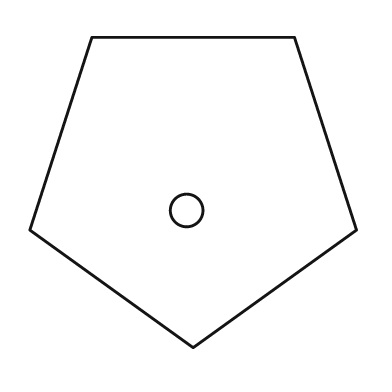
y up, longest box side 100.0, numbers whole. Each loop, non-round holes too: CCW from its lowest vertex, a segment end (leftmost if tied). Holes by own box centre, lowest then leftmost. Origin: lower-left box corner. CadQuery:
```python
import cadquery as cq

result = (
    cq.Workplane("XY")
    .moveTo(50.0, 0.0)
    .lineTo(100.0, 36.0)
    .lineTo(81.0, 95.0)
    .lineTo(19.0, 95.0)
    .lineTo(0.0, 36.0)
    .close()
    .moveTo(48.0, 42.0)
    .circle(5.0)
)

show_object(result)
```